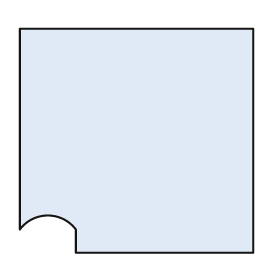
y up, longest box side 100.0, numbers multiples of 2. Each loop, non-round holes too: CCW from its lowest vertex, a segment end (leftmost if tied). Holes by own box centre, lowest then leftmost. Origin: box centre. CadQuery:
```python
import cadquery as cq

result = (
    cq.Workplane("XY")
    .moveTo(-26.0, -48.0)
    .lineTo(50.0, -48.0)
    .lineTo(50.0, 48.0)
    .lineTo(-50.0, 48.0)
    .lineTo(-50.0, -38.0)
    .threePointArc((-38.0, -32.0), (-26.0, -38.0))
    .close()
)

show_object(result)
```